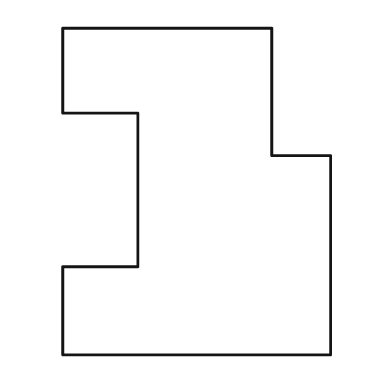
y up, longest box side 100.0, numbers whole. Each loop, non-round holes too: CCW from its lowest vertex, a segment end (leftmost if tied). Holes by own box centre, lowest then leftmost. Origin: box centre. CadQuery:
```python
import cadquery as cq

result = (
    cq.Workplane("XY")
    .moveTo(-41.0, -50.0)
    .lineTo(41.0, -50.0)
    .lineTo(41.0, 11.0)
    .lineTo(23.0, 11.0)
    .lineTo(23.0, 50.0)
    .lineTo(-41.0, 50.0)
    .lineTo(-41.0, 24.0)
    .lineTo(-18.0, 24.0)
    .lineTo(-18.0, -23.0)
    .lineTo(-41.0, -23.0)
    .close()
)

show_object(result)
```